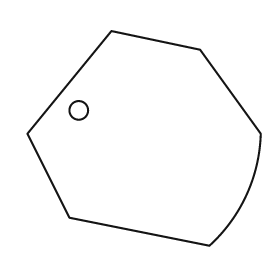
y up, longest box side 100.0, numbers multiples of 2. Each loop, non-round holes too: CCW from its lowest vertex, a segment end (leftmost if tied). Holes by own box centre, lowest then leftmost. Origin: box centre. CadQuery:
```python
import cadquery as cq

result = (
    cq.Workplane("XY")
    .moveTo(28.0, -46.0)
    .threePointArc((44.0, -24.0), (50.0, 2.0))
    .lineTo(24.0, 38.0)
    .lineTo(-14.0, 46.0)
    .lineTo(-50.0, 2.0)
    .lineTo(-32.0, -34.0)
    .close()
    .moveTo(-28.0, 12.0)
    .circle(4.0)
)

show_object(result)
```